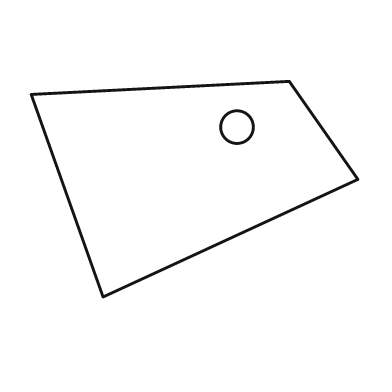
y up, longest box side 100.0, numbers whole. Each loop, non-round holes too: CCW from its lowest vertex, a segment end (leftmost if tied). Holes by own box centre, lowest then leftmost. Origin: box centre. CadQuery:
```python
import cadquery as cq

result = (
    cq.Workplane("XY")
    .moveTo(-28.0, -33.0)
    .lineTo(50.0, 3.0)
    .lineTo(29.0, 33.0)
    .lineTo(-50.0, 29.0)
    .close()
    .moveTo(13.0, 19.0)
    .circle(5.0)
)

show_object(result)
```